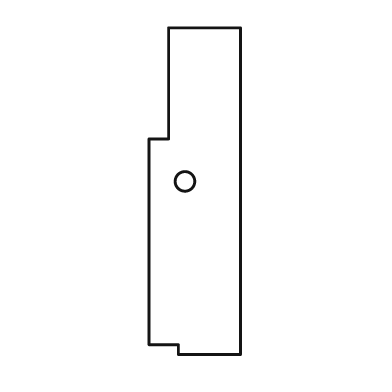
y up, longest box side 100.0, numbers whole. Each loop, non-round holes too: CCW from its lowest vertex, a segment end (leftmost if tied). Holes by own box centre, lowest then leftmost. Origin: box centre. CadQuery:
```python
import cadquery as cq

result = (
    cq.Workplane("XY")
    .moveTo(-5.0, -50.0)
    .lineTo(14.0, -50.0)
    .lineTo(14.0, 50.0)
    .lineTo(-8.0, 50.0)
    .lineTo(-8.0, 16.0)
    .lineTo(-14.0, 16.0)
    .lineTo(-14.0, -47.0)
    .lineTo(-5.0, -47.0)
    .close()
    .moveTo(-3.0, 3.0)
    .circle(3.0)
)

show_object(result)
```